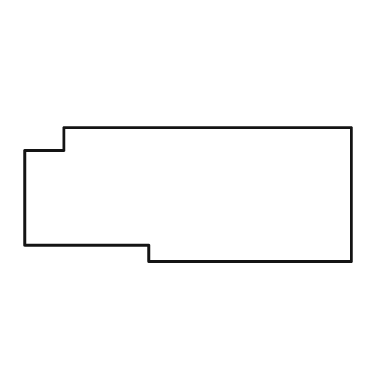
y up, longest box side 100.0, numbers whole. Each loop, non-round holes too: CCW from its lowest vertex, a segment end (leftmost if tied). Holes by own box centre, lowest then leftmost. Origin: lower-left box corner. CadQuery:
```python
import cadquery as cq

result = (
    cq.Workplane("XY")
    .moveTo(38.0, 0.0)
    .lineTo(100.0, 0.0)
    .lineTo(100.0, 41.0)
    .lineTo(12.0, 41.0)
    .lineTo(12.0, 34.0)
    .lineTo(0.0, 34.0)
    .lineTo(0.0, 5.0)
    .lineTo(38.0, 5.0)
    .close()
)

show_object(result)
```